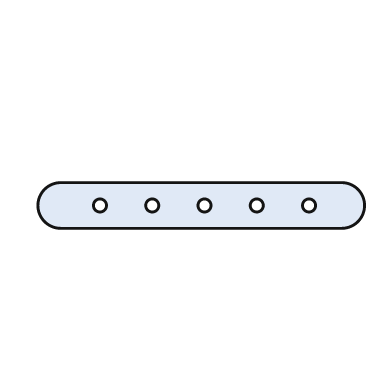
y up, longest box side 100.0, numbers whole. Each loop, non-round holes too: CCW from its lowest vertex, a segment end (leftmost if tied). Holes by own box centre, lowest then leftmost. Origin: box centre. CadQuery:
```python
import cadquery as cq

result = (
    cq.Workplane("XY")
    .moveTo(-43.0, -7.0)
    .lineTo(43.0, -7.0)
    .threePointArc((50.0, 0.0), (43.0, 7.0))
    .lineTo(-43.0, 7.0)
    .threePointArc((-50.0, 0.0), (-43.0, -7.0))
    .close()
    .moveTo(-31.0, 0.0)
    .circle(2.0)
    .moveTo(-15.0, 0.0)
    .circle(2.0)
    .moveTo(1.0, 0.0)
    .circle(2.0)
    .moveTo(17.0, 0.0)
    .circle(2.0)
    .moveTo(33.0, 0.0)
    .circle(2.0)
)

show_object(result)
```